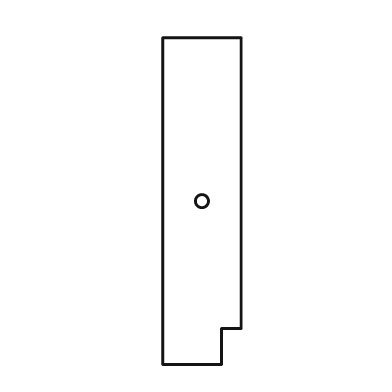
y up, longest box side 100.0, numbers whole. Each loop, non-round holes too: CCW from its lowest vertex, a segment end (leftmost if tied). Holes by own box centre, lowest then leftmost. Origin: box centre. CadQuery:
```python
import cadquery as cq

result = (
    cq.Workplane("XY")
    .moveTo(-12.0, -50.0)
    .lineTo(6.0, -50.0)
    .lineTo(6.0, -39.0)
    .lineTo(12.0, -39.0)
    .lineTo(12.0, 50.0)
    .lineTo(-12.0, 50.0)
    .close()
    .moveTo(0.0, 0.0)
    .circle(2.0)
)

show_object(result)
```